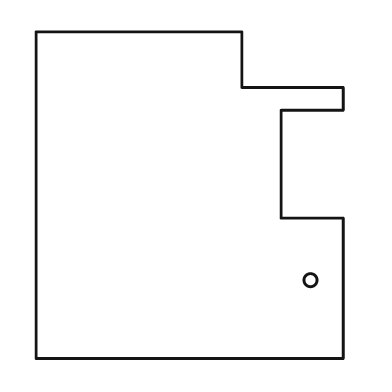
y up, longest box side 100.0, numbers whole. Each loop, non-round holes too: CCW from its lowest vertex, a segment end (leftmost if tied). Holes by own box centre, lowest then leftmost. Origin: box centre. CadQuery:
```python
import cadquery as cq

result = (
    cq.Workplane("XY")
    .moveTo(-47.0, -50.0)
    .lineTo(47.0, -50.0)
    .lineTo(47.0, -7.0)
    .lineTo(28.0, -7.0)
    .lineTo(28.0, 26.0)
    .lineTo(47.0, 26.0)
    .lineTo(47.0, 33.0)
    .lineTo(16.0, 33.0)
    .lineTo(16.0, 50.0)
    .lineTo(-47.0, 50.0)
    .close()
    .moveTo(37.0, -26.0)
    .circle(2.0)
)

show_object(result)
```